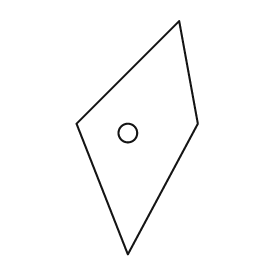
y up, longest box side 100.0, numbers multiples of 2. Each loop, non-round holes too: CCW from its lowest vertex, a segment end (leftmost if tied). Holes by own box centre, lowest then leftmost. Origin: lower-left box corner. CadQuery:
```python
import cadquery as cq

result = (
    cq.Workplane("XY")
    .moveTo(22.0, 0.0)
    .lineTo(52.0, 56.0)
    .lineTo(44.0, 100.0)
    .lineTo(0.0, 56.0)
    .close()
    .moveTo(22.0, 52.0)
    .circle(4.0)
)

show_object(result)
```